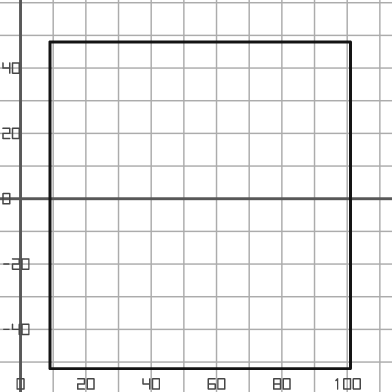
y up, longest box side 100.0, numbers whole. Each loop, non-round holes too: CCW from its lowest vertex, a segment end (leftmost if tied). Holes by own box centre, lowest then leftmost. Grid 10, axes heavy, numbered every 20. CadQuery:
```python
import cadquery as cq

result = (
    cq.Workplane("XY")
    .moveTo(9.0, -52.0)
    .lineTo(101.0, -52.0)
    .lineTo(101.0, 48.0)
    .lineTo(9.0, 48.0)
    .close()
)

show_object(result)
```